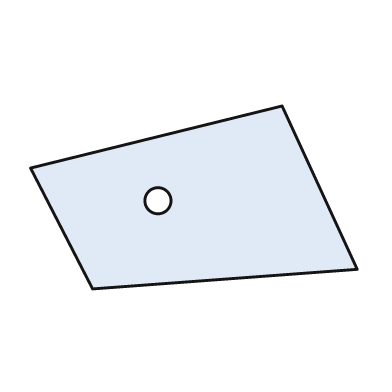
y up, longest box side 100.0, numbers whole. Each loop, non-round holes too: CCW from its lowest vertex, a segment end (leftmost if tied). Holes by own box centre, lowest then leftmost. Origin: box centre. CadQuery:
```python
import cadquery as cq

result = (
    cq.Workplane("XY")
    .moveTo(-31.0, -28.0)
    .lineTo(50.0, -22.0)
    .lineTo(27.0, 28.0)
    .lineTo(-50.0, 9.0)
    .close()
    .moveTo(-11.0, -1.0)
    .circle(4.0)
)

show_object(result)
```